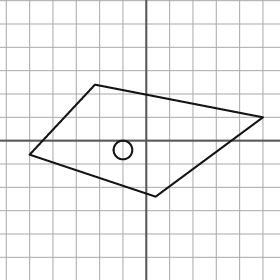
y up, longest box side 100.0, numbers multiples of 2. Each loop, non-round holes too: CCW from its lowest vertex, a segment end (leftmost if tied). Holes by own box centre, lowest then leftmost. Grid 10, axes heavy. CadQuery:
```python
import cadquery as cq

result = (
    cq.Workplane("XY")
    .moveTo(4.0, -24.0)
    .lineTo(50.0, 10.0)
    .lineTo(-22.0, 24.0)
    .lineTo(-50.0, -6.0)
    .close()
    .moveTo(-10.0, -4.0)
    .circle(4.0)
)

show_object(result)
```